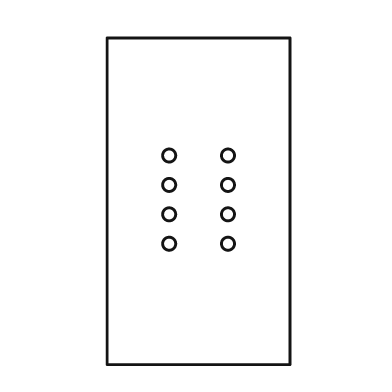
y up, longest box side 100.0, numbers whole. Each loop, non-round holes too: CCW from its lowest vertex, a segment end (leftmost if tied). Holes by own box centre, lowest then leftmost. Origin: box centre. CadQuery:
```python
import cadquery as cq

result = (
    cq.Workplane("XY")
    .moveTo(-28.0, -50.0)
    .lineTo(28.0, -50.0)
    .lineTo(28.0, 50.0)
    .lineTo(-28.0, 50.0)
    .close()
    .moveTo(-9.0, -13.0)
    .circle(2.0)
    .moveTo(9.0, -13.0)
    .circle(2.0)
    .moveTo(-9.0, -4.0)
    .circle(2.0)
    .moveTo(9.0, -4.0)
    .circle(2.0)
    .moveTo(-9.0, 5.0)
    .circle(2.0)
    .moveTo(9.0, 5.0)
    .circle(2.0)
    .moveTo(-9.0, 14.0)
    .circle(2.0)
    .moveTo(9.0, 14.0)
    .circle(2.0)
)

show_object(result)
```